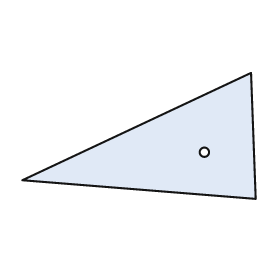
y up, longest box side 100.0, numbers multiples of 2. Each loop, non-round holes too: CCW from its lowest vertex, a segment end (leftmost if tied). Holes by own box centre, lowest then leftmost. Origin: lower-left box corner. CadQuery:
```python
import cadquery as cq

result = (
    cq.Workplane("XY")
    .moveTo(100.0, 0.0)
    .lineTo(98.0, 54.0)
    .lineTo(0.0, 8.0)
    .close()
    .moveTo(78.0, 20.0)
    .circle(2.0)
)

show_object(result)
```